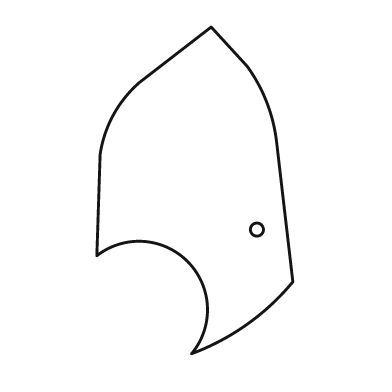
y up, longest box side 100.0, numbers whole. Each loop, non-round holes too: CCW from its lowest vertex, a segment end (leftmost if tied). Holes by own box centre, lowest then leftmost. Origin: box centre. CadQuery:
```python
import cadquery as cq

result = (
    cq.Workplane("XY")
    .moveTo(-1.0, -50.0)
    .threePointArc((16.0, -41.0), (30.0, -28.0))
    .lineTo(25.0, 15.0)
    .threePointArc((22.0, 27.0), (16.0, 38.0))
    .lineTo(5.0, 50.0)
    .lineTo(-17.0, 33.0)
    .threePointArc((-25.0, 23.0), (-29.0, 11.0))
    .lineTo(-30.0, -20.0)
    .threePointArc((-2.0, -22.0), (-1.0, -50.0))
    .close()
    .moveTo(19.0, -12.0)
    .circle(2.0)
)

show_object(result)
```